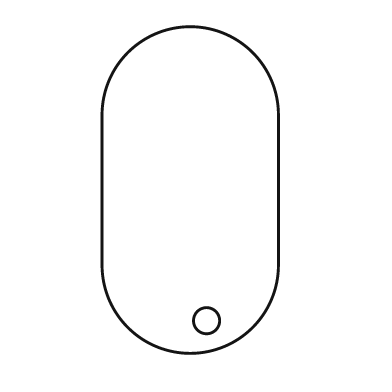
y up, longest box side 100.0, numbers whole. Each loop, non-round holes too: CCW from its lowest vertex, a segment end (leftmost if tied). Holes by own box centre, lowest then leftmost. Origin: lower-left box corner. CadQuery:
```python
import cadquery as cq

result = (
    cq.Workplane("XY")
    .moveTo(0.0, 27.0)
    .threePointArc((27.0, 0.0), (54.0, 27.0))
    .lineTo(54.0, 73.0)
    .threePointArc((27.0, 100.0), (0.0, 73.0))
    .close()
    .moveTo(32.0, 10.0)
    .circle(4.0)
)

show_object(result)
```